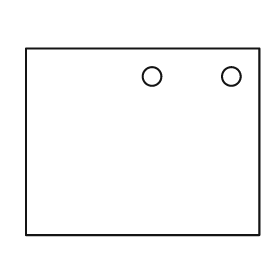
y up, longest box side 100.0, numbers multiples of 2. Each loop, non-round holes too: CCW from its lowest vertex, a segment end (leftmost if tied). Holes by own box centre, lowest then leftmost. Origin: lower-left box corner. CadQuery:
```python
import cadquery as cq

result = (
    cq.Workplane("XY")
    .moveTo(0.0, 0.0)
    .lineTo(100.0, 0.0)
    .lineTo(100.0, 80.0)
    .lineTo(0.0, 80.0)
    .close()
    .moveTo(54.0, 68.0)
    .circle(4.0)
    .moveTo(88.0, 68.0)
    .circle(4.0)
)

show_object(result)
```